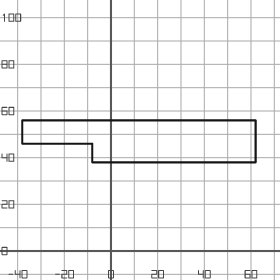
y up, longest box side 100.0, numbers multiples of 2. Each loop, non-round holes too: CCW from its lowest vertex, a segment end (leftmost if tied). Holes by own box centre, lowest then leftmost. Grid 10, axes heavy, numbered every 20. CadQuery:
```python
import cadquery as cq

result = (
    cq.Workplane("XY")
    .moveTo(-8.0, 38.0)
    .lineTo(62.0, 38.0)
    .lineTo(62.0, 56.0)
    .lineTo(-38.0, 56.0)
    .lineTo(-38.0, 46.0)
    .lineTo(-8.0, 46.0)
    .close()
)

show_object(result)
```